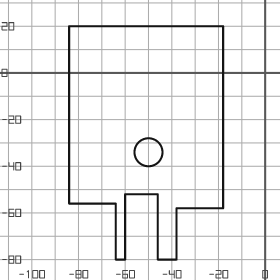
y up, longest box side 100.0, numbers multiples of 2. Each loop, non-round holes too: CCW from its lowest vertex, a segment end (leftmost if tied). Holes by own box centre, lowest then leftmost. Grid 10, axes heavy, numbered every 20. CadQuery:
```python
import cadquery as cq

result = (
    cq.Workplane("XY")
    .moveTo(-64.0, -80.0)
    .lineTo(-60.0, -80.0)
    .lineTo(-60.0, -52.0)
    .lineTo(-46.0, -52.0)
    .lineTo(-46.0, -80.0)
    .lineTo(-38.0, -80.0)
    .lineTo(-38.0, -58.0)
    .lineTo(-18.0, -58.0)
    .lineTo(-18.0, 20.0)
    .lineTo(-84.0, 20.0)
    .lineTo(-84.0, -56.0)
    .lineTo(-64.0, -56.0)
    .close()
    .moveTo(-50.0, -34.0)
    .circle(6.0)
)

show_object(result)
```